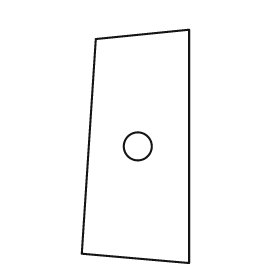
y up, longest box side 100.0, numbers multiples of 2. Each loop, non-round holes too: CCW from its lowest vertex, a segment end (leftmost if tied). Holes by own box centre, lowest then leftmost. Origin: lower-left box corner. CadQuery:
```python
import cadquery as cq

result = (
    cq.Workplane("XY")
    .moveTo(46.0, 0.0)
    .lineTo(46.0, 100.0)
    .lineTo(6.0, 96.0)
    .lineTo(0.0, 4.0)
    .close()
    .moveTo(24.0, 50.0)
    .circle(6.0)
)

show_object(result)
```